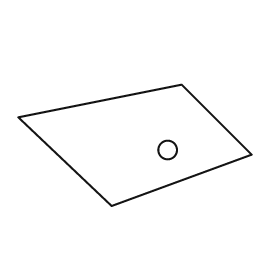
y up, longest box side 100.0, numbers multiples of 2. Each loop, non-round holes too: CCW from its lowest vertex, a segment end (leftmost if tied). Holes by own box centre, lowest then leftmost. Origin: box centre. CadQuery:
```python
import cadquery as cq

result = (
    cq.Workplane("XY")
    .moveTo(-10.0, -26.0)
    .lineTo(50.0, -4.0)
    .lineTo(20.0, 26.0)
    .lineTo(-50.0, 12.0)
    .close()
    .moveTo(14.0, -2.0)
    .circle(4.0)
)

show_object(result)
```